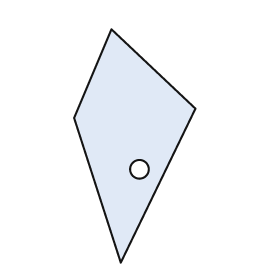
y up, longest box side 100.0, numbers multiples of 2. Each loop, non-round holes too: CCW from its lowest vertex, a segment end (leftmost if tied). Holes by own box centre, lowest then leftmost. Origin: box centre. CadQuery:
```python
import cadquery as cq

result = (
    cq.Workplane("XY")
    .moveTo(-6.0, -50.0)
    .lineTo(26.0, 16.0)
    .lineTo(-10.0, 50.0)
    .lineTo(-26.0, 12.0)
    .close()
    .moveTo(2.0, -10.0)
    .circle(4.0)
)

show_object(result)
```